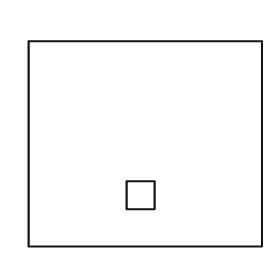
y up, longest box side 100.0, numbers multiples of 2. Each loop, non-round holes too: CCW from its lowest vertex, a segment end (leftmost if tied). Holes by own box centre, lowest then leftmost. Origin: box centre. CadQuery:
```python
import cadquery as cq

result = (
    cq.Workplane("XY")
    .moveTo(-50.0, -44.0)
    .lineTo(50.0, -44.0)
    .lineTo(50.0, 44.0)
    .lineTo(-50.0, 44.0)
    .close()
    .moveTo(-8.0, -28.0)
    .lineTo(4.0, -28.0)
    .lineTo(4.0, -16.0)
    .lineTo(-8.0, -16.0)
    .close()
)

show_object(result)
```